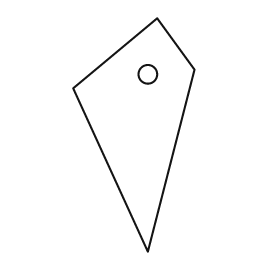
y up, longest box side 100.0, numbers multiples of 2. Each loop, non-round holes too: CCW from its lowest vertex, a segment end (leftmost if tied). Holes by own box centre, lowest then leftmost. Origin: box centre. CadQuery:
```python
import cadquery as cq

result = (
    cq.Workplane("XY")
    .moveTo(6.0, -50.0)
    .lineTo(26.0, 28.0)
    .lineTo(10.0, 50.0)
    .lineTo(-26.0, 20.0)
    .close()
    .moveTo(6.0, 26.0)
    .circle(4.0)
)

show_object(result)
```